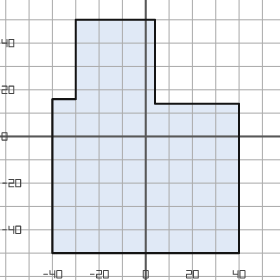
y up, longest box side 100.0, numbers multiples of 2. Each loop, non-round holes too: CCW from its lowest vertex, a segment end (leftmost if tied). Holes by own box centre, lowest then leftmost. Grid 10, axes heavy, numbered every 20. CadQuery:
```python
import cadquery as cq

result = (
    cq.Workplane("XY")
    .moveTo(-40.0, -50.0)
    .lineTo(40.0, -50.0)
    .lineTo(40.0, 14.0)
    .lineTo(4.0, 14.0)
    .lineTo(4.0, 50.0)
    .lineTo(-30.0, 50.0)
    .lineTo(-30.0, 16.0)
    .lineTo(-40.0, 16.0)
    .close()
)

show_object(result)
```